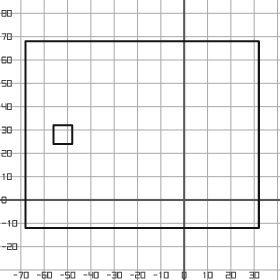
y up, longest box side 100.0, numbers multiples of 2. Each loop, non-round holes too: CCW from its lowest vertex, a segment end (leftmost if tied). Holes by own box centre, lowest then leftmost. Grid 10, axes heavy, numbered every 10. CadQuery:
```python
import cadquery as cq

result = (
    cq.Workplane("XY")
    .moveTo(-68.0, -12.0)
    .lineTo(32.0, -12.0)
    .lineTo(32.0, 68.0)
    .lineTo(-68.0, 68.0)
    .close()
    .moveTo(-56.0, 24.0)
    .lineTo(-48.0, 24.0)
    .lineTo(-48.0, 32.0)
    .lineTo(-56.0, 32.0)
    .close()
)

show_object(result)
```